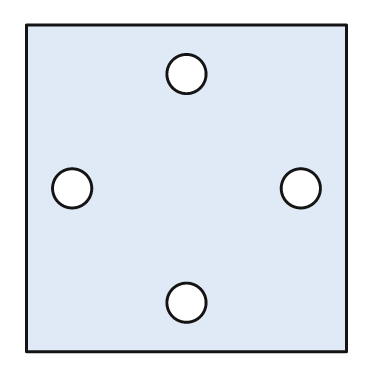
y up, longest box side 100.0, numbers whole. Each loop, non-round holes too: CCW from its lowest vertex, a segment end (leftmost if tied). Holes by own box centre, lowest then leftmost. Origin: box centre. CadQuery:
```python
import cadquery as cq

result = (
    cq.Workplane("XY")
    .moveTo(-49.0, -50.0)
    .lineTo(49.0, -50.0)
    .lineTo(49.0, 50.0)
    .lineTo(-49.0, 50.0)
    .close()
    .moveTo(0.0, -35.0)
    .circle(6.0)
    .moveTo(-35.0, 0.0)
    .circle(6.0)
    .moveTo(35.0, 0.0)
    .circle(6.0)
    .moveTo(0.0, 35.0)
    .circle(6.0)
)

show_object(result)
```